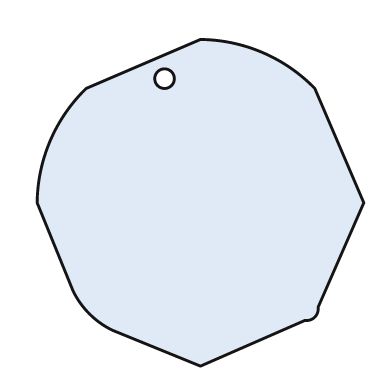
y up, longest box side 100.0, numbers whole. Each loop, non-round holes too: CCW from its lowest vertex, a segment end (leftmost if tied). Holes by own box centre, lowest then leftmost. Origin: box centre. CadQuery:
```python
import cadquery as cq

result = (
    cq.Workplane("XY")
    .moveTo(0.0, -50.0)
    .lineTo(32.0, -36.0)
    .threePointArc((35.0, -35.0), (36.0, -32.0))
    .lineTo(50.0, 0.0)
    .lineTo(35.0, 35.0)
    .threePointArc((19.0, 46.0), (0.0, 50.0))
    .lineTo(-35.0, 35.0)
    .threePointArc((-46.0, 19.0), (-50.0, 0.0))
    .lineTo(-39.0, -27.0)
    .threePointArc((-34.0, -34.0), (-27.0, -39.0))
    .close()
    .moveTo(-11.0, 38.0)
    .circle(3.0)
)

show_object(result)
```